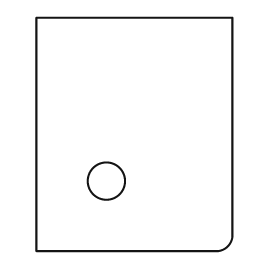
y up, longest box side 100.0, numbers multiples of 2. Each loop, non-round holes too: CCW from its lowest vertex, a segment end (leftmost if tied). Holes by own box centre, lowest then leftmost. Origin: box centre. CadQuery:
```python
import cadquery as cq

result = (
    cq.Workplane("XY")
    .moveTo(-42.0, -50.0)
    .lineTo(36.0, -50.0)
    .threePointArc((40.0, -48.0), (42.0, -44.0))
    .lineTo(42.0, 50.0)
    .lineTo(-42.0, 50.0)
    .close()
    .moveTo(-12.0, -20.0)
    .circle(8.0)
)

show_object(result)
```